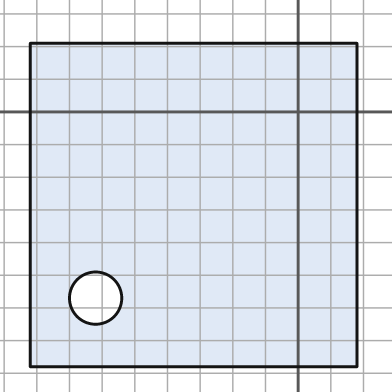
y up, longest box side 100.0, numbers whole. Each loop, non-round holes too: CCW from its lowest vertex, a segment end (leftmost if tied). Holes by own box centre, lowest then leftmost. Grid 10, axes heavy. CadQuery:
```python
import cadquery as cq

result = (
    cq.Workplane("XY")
    .moveTo(-82.0, -78.0)
    .lineTo(18.0, -78.0)
    .lineTo(18.0, 21.0)
    .lineTo(-82.0, 21.0)
    .close()
    .moveTo(-62.0, -57.0)
    .circle(8.0)
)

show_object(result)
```